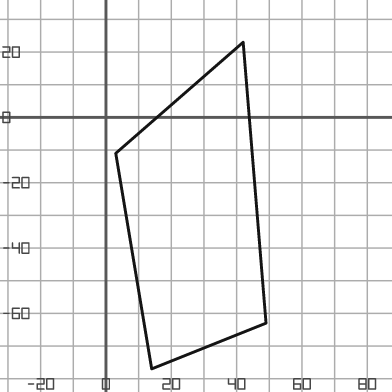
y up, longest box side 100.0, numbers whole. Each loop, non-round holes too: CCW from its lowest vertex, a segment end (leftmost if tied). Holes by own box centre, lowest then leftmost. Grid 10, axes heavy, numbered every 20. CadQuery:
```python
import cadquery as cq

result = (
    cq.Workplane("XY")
    .moveTo(14.0, -77.0)
    .lineTo(49.0, -63.0)
    .lineTo(42.0, 23.0)
    .lineTo(3.0, -11.0)
    .close()
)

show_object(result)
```